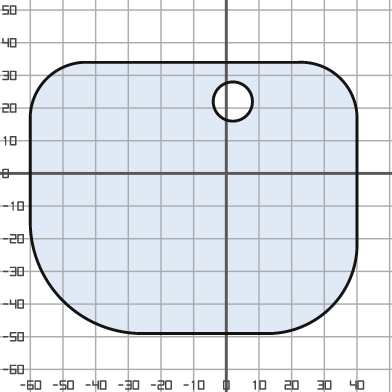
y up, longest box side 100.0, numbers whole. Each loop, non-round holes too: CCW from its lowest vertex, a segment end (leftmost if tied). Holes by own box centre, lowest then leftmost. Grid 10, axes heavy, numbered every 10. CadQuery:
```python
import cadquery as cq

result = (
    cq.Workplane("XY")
    .moveTo(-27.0, -49.0)
    .lineTo(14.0, -49.0)
    .threePointArc((32.0, -41.0), (40.0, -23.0))
    .lineTo(40.0, 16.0)
    .threePointArc((35.0, 29.0), (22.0, 34.0))
    .lineTo(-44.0, 34.0)
    .threePointArc((-55.0, 29.0), (-60.0, 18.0))
    .lineTo(-60.0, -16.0)
    .threePointArc((-50.0, -39.0), (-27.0, -49.0))
    .close()
    .moveTo(2.0, 22.0)
    .circle(6.0)
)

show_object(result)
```